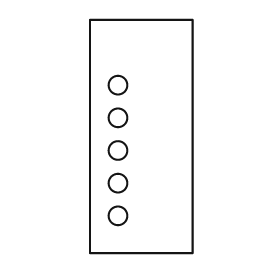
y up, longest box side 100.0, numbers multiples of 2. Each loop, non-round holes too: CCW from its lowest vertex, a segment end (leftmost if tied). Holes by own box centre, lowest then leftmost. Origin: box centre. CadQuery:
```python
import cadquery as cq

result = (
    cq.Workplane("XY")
    .moveTo(-22.0, -50.0)
    .lineTo(22.0, -50.0)
    .lineTo(22.0, 50.0)
    .lineTo(-22.0, 50.0)
    .close()
    .moveTo(-10.0, -34.0)
    .circle(4.0)
    .moveTo(-10.0, -20.0)
    .circle(4.0)
    .moveTo(-10.0, -6.0)
    .circle(4.0)
    .moveTo(-10.0, 8.0)
    .circle(4.0)
    .moveTo(-10.0, 22.0)
    .circle(4.0)
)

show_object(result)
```